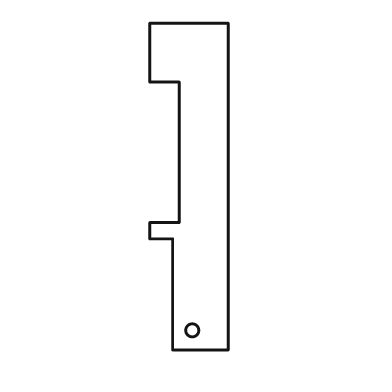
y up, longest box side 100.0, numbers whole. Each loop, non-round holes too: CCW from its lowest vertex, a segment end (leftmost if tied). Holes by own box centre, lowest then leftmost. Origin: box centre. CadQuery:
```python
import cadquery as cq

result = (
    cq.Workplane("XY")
    .moveTo(-5.0, -50.0)
    .lineTo(12.0, -50.0)
    .lineTo(12.0, 50.0)
    .lineTo(-12.0, 50.0)
    .lineTo(-12.0, 32.0)
    .lineTo(-3.0, 32.0)
    .lineTo(-3.0, -11.0)
    .lineTo(-12.0, -11.0)
    .lineTo(-12.0, -16.0)
    .lineTo(-5.0, -16.0)
    .close()
    .moveTo(1.0, -44.0)
    .circle(2.0)
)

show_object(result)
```